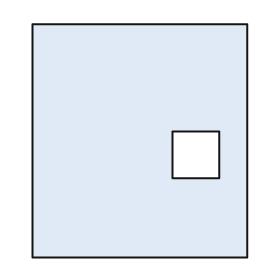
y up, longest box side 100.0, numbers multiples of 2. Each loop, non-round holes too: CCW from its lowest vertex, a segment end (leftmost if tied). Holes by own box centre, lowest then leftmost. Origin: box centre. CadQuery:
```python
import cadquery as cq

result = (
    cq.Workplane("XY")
    .moveTo(-46.0, -50.0)
    .lineTo(46.0, -50.0)
    .lineTo(46.0, 50.0)
    .lineTo(-46.0, 50.0)
    .close()
    .moveTo(14.0, -16.0)
    .lineTo(34.0, -16.0)
    .lineTo(34.0, 4.0)
    .lineTo(14.0, 4.0)
    .close()
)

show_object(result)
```